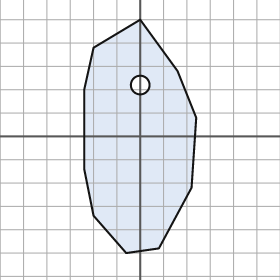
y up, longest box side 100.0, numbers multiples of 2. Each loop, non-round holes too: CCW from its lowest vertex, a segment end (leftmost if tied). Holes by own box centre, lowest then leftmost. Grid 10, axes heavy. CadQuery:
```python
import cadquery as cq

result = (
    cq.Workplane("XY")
    .moveTo(-6.0, -50.0)
    .lineTo(8.0, -48.0)
    .lineTo(22.0, -22.0)
    .lineTo(24.0, 8.0)
    .lineTo(16.0, 28.0)
    .lineTo(0.0, 50.0)
    .lineTo(-20.0, 38.0)
    .lineTo(-24.0, 20.0)
    .lineTo(-24.0, -14.0)
    .lineTo(-20.0, -34.0)
    .close()
    .moveTo(0.0, 22.0)
    .circle(4.0)
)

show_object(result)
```